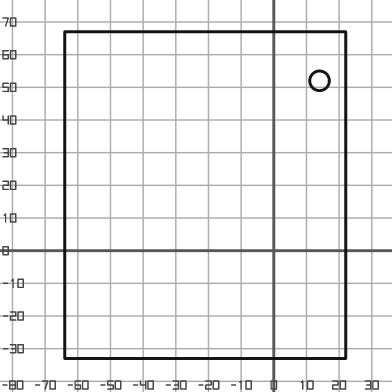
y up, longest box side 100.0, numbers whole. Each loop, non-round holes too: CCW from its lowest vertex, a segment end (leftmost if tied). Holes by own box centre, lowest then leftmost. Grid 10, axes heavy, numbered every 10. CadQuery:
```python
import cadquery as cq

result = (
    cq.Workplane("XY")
    .moveTo(-64.0, -33.0)
    .lineTo(22.0, -33.0)
    .lineTo(22.0, 67.0)
    .lineTo(-64.0, 67.0)
    .close()
    .moveTo(14.0, 52.0)
    .circle(3.0)
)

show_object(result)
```